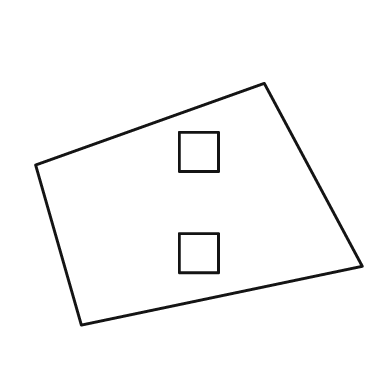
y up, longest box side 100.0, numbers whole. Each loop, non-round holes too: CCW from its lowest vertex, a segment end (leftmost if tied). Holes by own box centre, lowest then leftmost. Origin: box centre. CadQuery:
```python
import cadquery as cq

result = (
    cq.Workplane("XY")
    .moveTo(-36.0, -37.0)
    .lineTo(50.0, -19.0)
    .lineTo(20.0, 37.0)
    .lineTo(-50.0, 12.0)
    .close()
    .moveTo(-6.0, -21.0)
    .lineTo(6.0, -21.0)
    .lineTo(6.0, -9.0)
    .lineTo(-6.0, -9.0)
    .close()
    .moveTo(-6.0, 10.0)
    .lineTo(6.0, 10.0)
    .lineTo(6.0, 22.0)
    .lineTo(-6.0, 22.0)
    .close()
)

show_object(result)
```